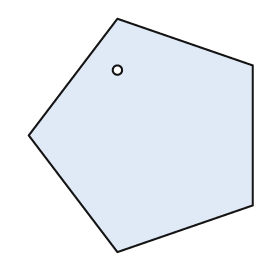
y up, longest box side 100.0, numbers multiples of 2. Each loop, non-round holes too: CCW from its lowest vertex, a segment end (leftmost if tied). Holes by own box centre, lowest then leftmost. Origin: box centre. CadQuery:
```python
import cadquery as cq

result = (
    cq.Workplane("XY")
    .moveTo(-10.0, -50.0)
    .lineTo(48.0, -30.0)
    .lineTo(48.0, 30.0)
    .lineTo(-10.0, 50.0)
    .lineTo(-48.0, 0.0)
    .close()
    .moveTo(-10.0, 28.0)
    .circle(2.0)
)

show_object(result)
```